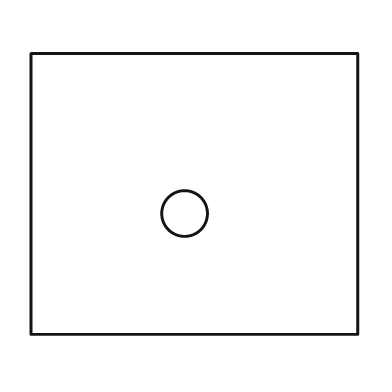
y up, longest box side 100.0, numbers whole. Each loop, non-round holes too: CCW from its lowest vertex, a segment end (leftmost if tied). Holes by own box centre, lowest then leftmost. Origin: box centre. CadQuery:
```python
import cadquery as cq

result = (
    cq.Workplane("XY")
    .moveTo(-50.0, -43.0)
    .lineTo(50.0, -43.0)
    .lineTo(50.0, 43.0)
    .lineTo(-50.0, 43.0)
    .close()
    .moveTo(-3.0, -6.0)
    .circle(7.0)
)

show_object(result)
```